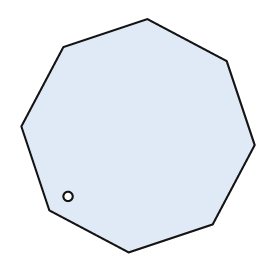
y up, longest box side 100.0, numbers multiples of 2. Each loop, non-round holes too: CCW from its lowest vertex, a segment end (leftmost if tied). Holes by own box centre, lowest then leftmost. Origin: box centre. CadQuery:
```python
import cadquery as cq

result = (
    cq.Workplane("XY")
    .moveTo(-4.0, -50.0)
    .lineTo(32.0, -38.0)
    .lineTo(50.0, -4.0)
    .lineTo(38.0, 32.0)
    .lineTo(4.0, 50.0)
    .lineTo(-32.0, 38.0)
    .lineTo(-50.0, 4.0)
    .lineTo(-38.0, -32.0)
    .close()
    .moveTo(-30.0, -26.0)
    .circle(2.0)
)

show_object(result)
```